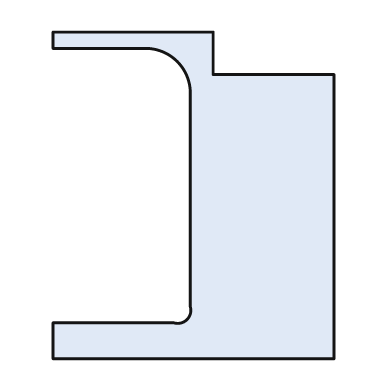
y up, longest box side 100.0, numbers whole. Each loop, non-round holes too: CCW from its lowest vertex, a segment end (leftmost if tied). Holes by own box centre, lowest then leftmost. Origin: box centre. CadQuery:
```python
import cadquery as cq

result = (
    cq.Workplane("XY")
    .moveTo(-43.0, -50.0)
    .lineTo(43.0, -50.0)
    .lineTo(43.0, 37.0)
    .lineTo(6.0, 37.0)
    .lineTo(6.0, 50.0)
    .lineTo(-43.0, 50.0)
    .lineTo(-43.0, 45.0)
    .lineTo(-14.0, 45.0)
    .threePointArc((-5.0, 41.0), (-1.0, 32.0))
    .lineTo(-1.0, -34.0)
    .threePointArc((-2.0, -38.0), (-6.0, -39.0))
    .lineTo(-43.0, -39.0)
    .close()
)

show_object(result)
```